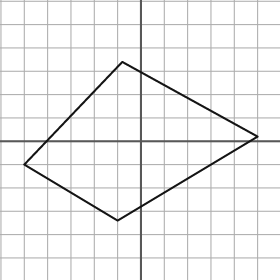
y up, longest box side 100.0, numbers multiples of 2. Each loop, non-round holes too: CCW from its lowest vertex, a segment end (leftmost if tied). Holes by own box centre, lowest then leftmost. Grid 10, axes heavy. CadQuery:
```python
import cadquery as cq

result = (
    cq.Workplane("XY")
    .moveTo(-10.0, -34.0)
    .lineTo(50.0, 2.0)
    .lineTo(-8.0, 34.0)
    .lineTo(-50.0, -10.0)
    .close()
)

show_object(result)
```